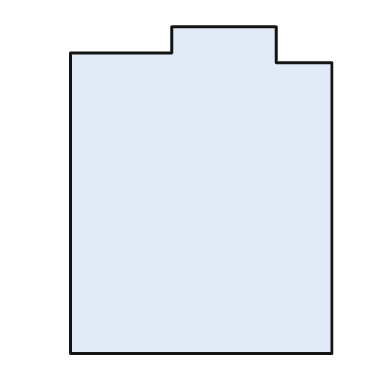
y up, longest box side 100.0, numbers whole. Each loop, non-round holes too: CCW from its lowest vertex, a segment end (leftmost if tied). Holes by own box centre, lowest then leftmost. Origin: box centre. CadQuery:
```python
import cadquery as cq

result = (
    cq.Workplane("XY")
    .moveTo(-40.0, -50.0)
    .lineTo(40.0, -50.0)
    .lineTo(40.0, 39.0)
    .lineTo(23.0, 39.0)
    .lineTo(23.0, 50.0)
    .lineTo(-9.0, 50.0)
    .lineTo(-9.0, 42.0)
    .lineTo(-40.0, 42.0)
    .close()
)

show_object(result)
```